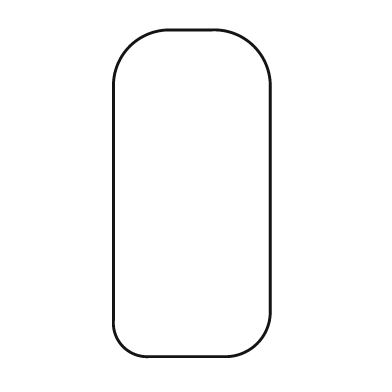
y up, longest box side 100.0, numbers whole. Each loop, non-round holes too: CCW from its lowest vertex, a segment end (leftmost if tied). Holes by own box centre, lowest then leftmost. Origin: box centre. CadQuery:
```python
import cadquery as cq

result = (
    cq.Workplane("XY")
    .moveTo(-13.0, -50.0)
    .lineTo(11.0, -50.0)
    .threePointArc((20.0, -46.0), (24.0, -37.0))
    .lineTo(24.0, 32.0)
    .threePointArc((19.0, 45.0), (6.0, 50.0))
    .lineTo(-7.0, 50.0)
    .threePointArc((-19.0, 45.0), (-24.0, 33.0))
    .lineTo(-24.0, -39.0)
    .threePointArc((-21.0, -47.0), (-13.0, -50.0))
    .close()
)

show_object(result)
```